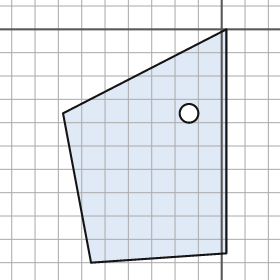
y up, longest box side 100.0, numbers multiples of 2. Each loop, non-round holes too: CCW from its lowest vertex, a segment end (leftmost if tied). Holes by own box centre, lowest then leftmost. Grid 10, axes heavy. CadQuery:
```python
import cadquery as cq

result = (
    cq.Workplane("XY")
    .moveTo(-56.0, -100.0)
    .lineTo(2.0, -96.0)
    .lineTo(2.0, 0.0)
    .lineTo(-68.0, -36.0)
    .close()
    .moveTo(-14.0, -36.0)
    .circle(4.0)
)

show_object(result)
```